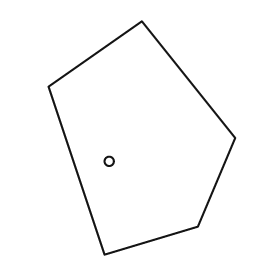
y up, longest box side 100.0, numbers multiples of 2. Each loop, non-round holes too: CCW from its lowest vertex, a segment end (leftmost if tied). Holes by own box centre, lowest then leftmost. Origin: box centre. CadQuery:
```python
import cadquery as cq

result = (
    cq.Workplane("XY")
    .moveTo(-16.0, -50.0)
    .lineTo(24.0, -38.0)
    .lineTo(40.0, 0.0)
    .lineTo(0.0, 50.0)
    .lineTo(-40.0, 22.0)
    .close()
    .moveTo(-14.0, -10.0)
    .circle(2.0)
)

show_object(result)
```